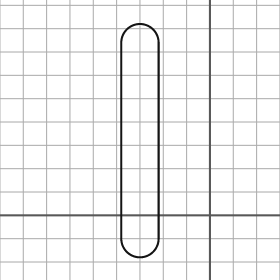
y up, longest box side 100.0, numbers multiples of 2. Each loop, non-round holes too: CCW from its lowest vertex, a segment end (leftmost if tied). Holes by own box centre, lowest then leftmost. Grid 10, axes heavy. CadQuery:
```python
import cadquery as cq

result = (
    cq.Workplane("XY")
    .moveTo(-38.0, -10.0)
    .threePointArc((-30.0, -18.0), (-22.0, -10.0))
    .lineTo(-22.0, 74.0)
    .threePointArc((-30.0, 82.0), (-38.0, 74.0))
    .close()
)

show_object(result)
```